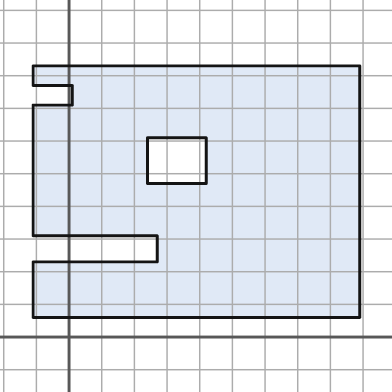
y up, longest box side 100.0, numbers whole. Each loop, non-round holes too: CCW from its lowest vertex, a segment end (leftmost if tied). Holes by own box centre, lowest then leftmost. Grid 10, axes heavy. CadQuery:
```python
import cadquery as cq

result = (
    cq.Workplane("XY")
    .moveTo(-11.0, 6.0)
    .lineTo(89.0, 6.0)
    .lineTo(89.0, 83.0)
    .lineTo(-11.0, 83.0)
    .lineTo(-11.0, 77.0)
    .lineTo(1.0, 77.0)
    .lineTo(1.0, 71.0)
    .lineTo(-11.0, 71.0)
    .lineTo(-11.0, 31.0)
    .lineTo(27.0, 31.0)
    .lineTo(27.0, 23.0)
    .lineTo(-11.0, 23.0)
    .close()
    .moveTo(24.0, 47.0)
    .lineTo(42.0, 47.0)
    .lineTo(42.0, 61.0)
    .lineTo(24.0, 61.0)
    .close()
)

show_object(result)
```